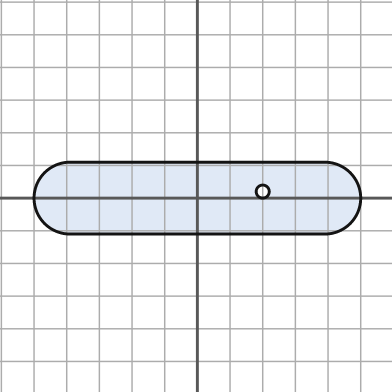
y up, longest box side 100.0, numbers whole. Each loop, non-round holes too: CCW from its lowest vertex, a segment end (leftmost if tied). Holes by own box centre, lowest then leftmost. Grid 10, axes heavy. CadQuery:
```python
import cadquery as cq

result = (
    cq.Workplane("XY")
    .moveTo(-39.0, -11.0)
    .lineTo(39.0, -11.0)
    .threePointArc((50.0, 0.0), (39.0, 11.0))
    .lineTo(-39.0, 11.0)
    .threePointArc((-50.0, 0.0), (-39.0, -11.0))
    .close()
    .moveTo(20.0, 2.0)
    .circle(2.0)
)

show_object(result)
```